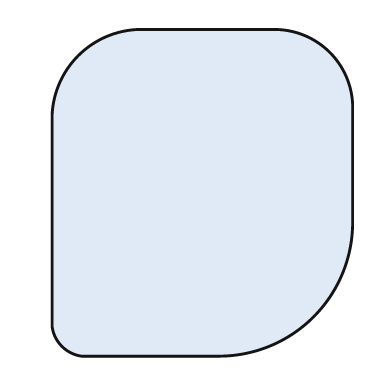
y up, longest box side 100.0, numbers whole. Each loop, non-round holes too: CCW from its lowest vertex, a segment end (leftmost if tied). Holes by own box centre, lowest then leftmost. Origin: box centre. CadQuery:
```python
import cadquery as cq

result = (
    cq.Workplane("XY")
    .moveTo(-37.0, -50.0)
    .lineTo(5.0, -50.0)
    .threePointArc((34.0, -38.0), (46.0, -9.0))
    .lineTo(46.0, 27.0)
    .threePointArc((39.0, 43.0), (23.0, 50.0))
    .lineTo(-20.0, 50.0)
    .threePointArc((-38.0, 42.0), (-46.0, 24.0))
    .lineTo(-46.0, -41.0)
    .threePointArc((-43.0, -47.0), (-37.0, -50.0))
    .close()
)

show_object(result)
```